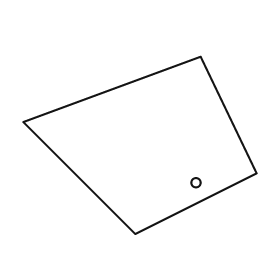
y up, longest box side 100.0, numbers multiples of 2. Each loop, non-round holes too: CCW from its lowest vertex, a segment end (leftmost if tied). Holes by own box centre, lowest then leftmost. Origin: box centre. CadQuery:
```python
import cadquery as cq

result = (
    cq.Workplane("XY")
    .moveTo(-2.0, -38.0)
    .lineTo(50.0, -12.0)
    .lineTo(26.0, 38.0)
    .lineTo(-50.0, 10.0)
    .close()
    .moveTo(24.0, -16.0)
    .circle(2.0)
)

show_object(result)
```